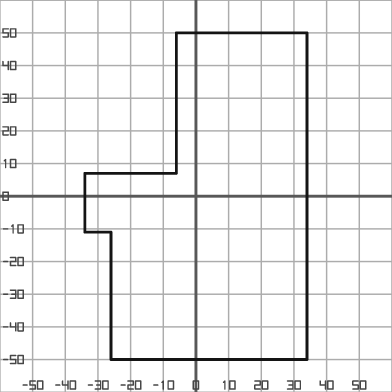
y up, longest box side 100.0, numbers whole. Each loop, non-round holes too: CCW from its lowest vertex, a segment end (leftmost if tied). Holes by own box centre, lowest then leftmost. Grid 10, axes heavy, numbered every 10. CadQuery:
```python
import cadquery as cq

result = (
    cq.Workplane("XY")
    .moveTo(-26.0, -50.0)
    .lineTo(34.0, -50.0)
    .lineTo(34.0, 50.0)
    .lineTo(-6.0, 50.0)
    .lineTo(-6.0, 7.0)
    .lineTo(-34.0, 7.0)
    .lineTo(-34.0, -11.0)
    .lineTo(-26.0, -11.0)
    .close()
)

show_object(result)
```